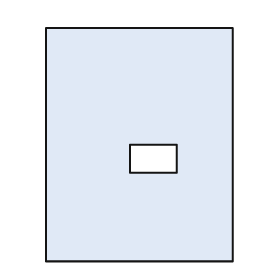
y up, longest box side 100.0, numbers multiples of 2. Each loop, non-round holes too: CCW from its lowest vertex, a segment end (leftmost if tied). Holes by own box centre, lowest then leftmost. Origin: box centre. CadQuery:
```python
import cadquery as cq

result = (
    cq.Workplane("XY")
    .moveTo(-40.0, -50.0)
    .lineTo(40.0, -50.0)
    .lineTo(40.0, 50.0)
    .lineTo(-40.0, 50.0)
    .close()
    .moveTo(-4.0, -12.0)
    .lineTo(16.0, -12.0)
    .lineTo(16.0, 0.0)
    .lineTo(-4.0, 0.0)
    .close()
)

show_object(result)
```